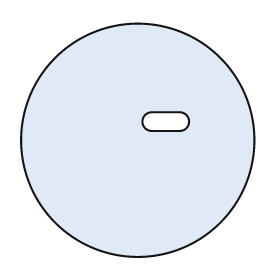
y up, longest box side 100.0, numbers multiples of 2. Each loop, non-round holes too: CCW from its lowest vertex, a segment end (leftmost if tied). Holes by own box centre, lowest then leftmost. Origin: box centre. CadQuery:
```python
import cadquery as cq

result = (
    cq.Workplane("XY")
    .moveTo(0.0, 0.0)
    .circle(50.0)
    .moveTo(6.0, 4.0)
    .lineTo(18.0, 4.0)
    .threePointArc((22.0, 8.0), (18.0, 12.0))
    .lineTo(6.0, 12.0)
    .threePointArc((2.0, 8.0), (6.0, 4.0))
    .close()
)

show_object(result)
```